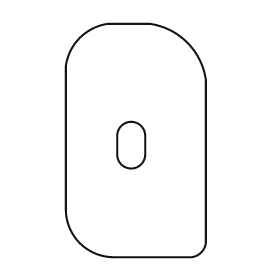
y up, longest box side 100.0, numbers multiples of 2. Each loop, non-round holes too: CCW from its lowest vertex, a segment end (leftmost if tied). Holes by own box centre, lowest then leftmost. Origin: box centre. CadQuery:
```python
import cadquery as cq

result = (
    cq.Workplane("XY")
    .moveTo(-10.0, -50.0)
    .lineTo(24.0, -50.0)
    .threePointArc((28.0, -48.0), (30.0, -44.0))
    .lineTo(30.0, 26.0)
    .threePointArc((22.0, 42.0), (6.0, 50.0))
    .lineTo(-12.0, 50.0)
    .threePointArc((-24.0, 44.0), (-30.0, 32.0))
    .lineTo(-30.0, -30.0)
    .threePointArc((-24.0, -44.0), (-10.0, -50.0))
    .close()
    .moveTo(-8.0, -6.0)
    .threePointArc((-2.0, -12.0), (4.0, -6.0))
    .lineTo(4.0, 2.0)
    .threePointArc((-2.0, 8.0), (-8.0, 2.0))
    .close()
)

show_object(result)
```